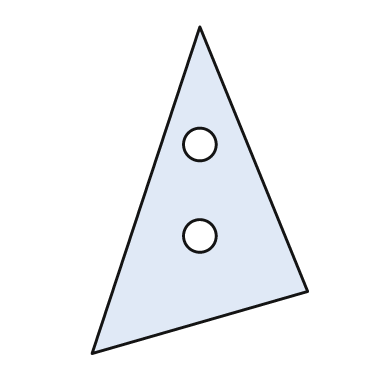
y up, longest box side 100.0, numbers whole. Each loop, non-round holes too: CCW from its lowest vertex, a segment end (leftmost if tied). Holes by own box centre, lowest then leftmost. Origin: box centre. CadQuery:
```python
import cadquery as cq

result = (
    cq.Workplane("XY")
    .moveTo(-33.0, -50.0)
    .lineTo(33.0, -31.0)
    .lineTo(0.0, 50.0)
    .close()
    .moveTo(0.0, -14.0)
    .circle(5.0)
    .moveTo(0.0, 14.0)
    .circle(5.0)
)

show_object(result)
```